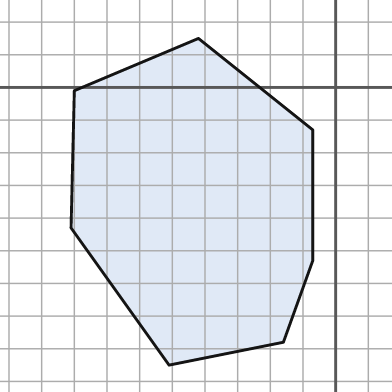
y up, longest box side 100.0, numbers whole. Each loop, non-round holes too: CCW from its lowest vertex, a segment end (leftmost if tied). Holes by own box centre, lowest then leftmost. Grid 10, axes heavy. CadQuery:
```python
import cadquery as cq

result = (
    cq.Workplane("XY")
    .moveTo(-51.0, -85.0)
    .lineTo(-16.0, -78.0)
    .lineTo(-7.0, -53.0)
    .lineTo(-7.0, -13.0)
    .lineTo(-42.0, 15.0)
    .lineTo(-80.0, -1.0)
    .lineTo(-81.0, -43.0)
    .close()
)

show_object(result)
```